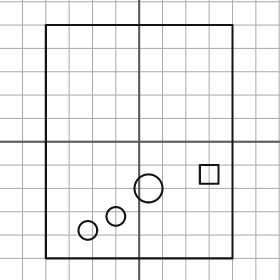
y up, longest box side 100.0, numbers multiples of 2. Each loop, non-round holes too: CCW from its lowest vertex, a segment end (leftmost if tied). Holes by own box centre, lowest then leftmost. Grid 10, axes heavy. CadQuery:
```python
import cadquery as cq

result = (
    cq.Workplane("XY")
    .moveTo(-40.0, -50.0)
    .lineTo(40.0, -50.0)
    .lineTo(40.0, 50.0)
    .lineTo(-40.0, 50.0)
    .close()
    .moveTo(-22.0, -38.0)
    .circle(4.0)
    .moveTo(-10.0, -32.0)
    .circle(4.0)
    .moveTo(4.0, -20.0)
    .circle(6.0)
    .moveTo(26.0, -18.0)
    .lineTo(34.0, -18.0)
    .lineTo(34.0, -10.0)
    .lineTo(26.0, -10.0)
    .close()
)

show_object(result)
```